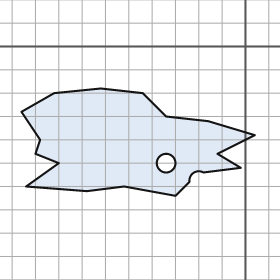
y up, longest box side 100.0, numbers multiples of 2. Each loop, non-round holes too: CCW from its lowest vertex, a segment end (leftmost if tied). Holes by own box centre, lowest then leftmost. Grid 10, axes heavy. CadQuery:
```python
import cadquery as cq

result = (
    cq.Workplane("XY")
    .moveTo(-30.0, -64.0)
    .lineTo(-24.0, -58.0)
    .threePointArc((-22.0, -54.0), (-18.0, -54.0))
    .lineTo(-2.0, -52.0)
    .lineTo(-12.0, -46.0)
    .lineTo(4.0, -38.0)
    .lineTo(-16.0, -32.0)
    .lineTo(-34.0, -30.0)
    .lineTo(-44.0, -20.0)
    .lineTo(-62.0, -18.0)
    .lineTo(-82.0, -20.0)
    .lineTo(-96.0, -28.0)
    .lineTo(-88.0, -40.0)
    .lineTo(-90.0, -46.0)
    .lineTo(-80.0, -50.0)
    .lineTo(-94.0, -60.0)
    .lineTo(-68.0, -62.0)
    .lineTo(-52.0, -60.0)
    .close()
    .moveTo(-34.0, -50.0)
    .circle(4.0)
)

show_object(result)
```